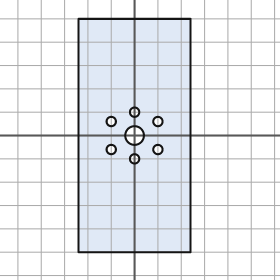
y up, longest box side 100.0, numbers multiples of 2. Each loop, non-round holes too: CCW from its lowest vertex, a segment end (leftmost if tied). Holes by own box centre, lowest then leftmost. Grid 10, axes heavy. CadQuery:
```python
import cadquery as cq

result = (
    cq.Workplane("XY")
    .moveTo(-24.0, -50.0)
    .lineTo(24.0, -50.0)
    .lineTo(24.0, 50.0)
    .lineTo(-24.0, 50.0)
    .close()
    .moveTo(0.0, -10.0)
    .circle(2.0)
    .moveTo(-10.0, -6.0)
    .circle(2.0)
    .moveTo(10.0, -6.0)
    .circle(2.0)
    .moveTo(0.0, 0.0)
    .circle(4.0)
    .moveTo(-10.0, 6.0)
    .circle(2.0)
    .moveTo(10.0, 6.0)
    .circle(2.0)
    .moveTo(0.0, 10.0)
    .circle(2.0)
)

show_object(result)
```